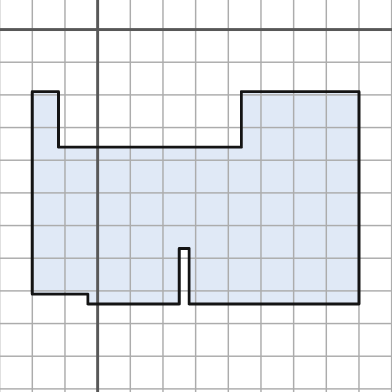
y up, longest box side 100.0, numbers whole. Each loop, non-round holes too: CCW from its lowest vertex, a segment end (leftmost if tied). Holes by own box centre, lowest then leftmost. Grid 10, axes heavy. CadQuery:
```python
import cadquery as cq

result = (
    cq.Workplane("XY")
    .moveTo(-3.0, -84.0)
    .lineTo(25.0, -84.0)
    .lineTo(25.0, -67.0)
    .lineTo(28.0, -67.0)
    .lineTo(28.0, -84.0)
    .lineTo(80.0, -84.0)
    .lineTo(80.0, -19.0)
    .lineTo(44.0, -19.0)
    .lineTo(44.0, -36.0)
    .lineTo(-12.0, -36.0)
    .lineTo(-12.0, -19.0)
    .lineTo(-20.0, -19.0)
    .lineTo(-20.0, -81.0)
    .lineTo(-3.0, -81.0)
    .close()
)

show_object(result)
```